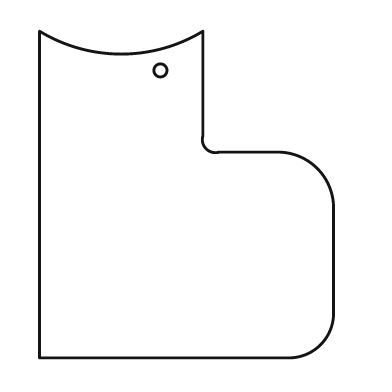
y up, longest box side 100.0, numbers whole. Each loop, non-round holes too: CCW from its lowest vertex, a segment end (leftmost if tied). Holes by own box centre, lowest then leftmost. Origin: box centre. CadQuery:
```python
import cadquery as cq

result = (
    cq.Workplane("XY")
    .moveTo(-45.0, -50.0)
    .lineTo(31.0, -50.0)
    .threePointArc((41.0, -46.0), (45.0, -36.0))
    .lineTo(45.0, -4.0)
    .threePointArc((40.0, 8.0), (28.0, 13.0))
    .lineTo(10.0, 13.0)
    .threePointArc((6.0, 14.0), (5.0, 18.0))
    .lineTo(5.0, 50.0)
    .threePointArc((-20.0, 43.0), (-45.0, 50.0))
    .close()
    .moveTo(-8.0, 38.0)
    .circle(2.0)
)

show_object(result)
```